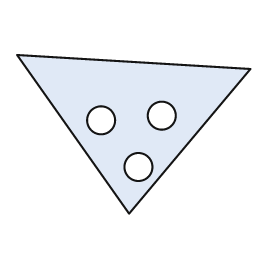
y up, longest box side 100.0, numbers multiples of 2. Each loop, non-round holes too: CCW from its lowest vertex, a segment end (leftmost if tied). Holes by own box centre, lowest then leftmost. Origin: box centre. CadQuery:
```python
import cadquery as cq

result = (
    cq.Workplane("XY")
    .moveTo(-2.0, -34.0)
    .lineTo(50.0, 28.0)
    .lineTo(-50.0, 34.0)
    .close()
    .moveTo(2.0, -14.0)
    .circle(6.0)
    .moveTo(-14.0, 6.0)
    .circle(6.0)
    .moveTo(12.0, 8.0)
    .circle(6.0)
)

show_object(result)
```